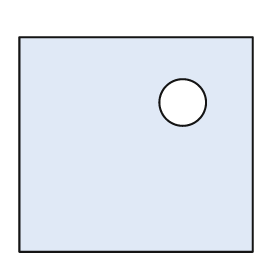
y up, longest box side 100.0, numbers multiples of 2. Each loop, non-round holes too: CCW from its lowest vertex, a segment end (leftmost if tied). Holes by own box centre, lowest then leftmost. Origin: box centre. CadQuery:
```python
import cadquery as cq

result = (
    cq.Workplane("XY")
    .moveTo(-50.0, -46.0)
    .lineTo(50.0, -46.0)
    .lineTo(50.0, 46.0)
    .lineTo(-50.0, 46.0)
    .close()
    .moveTo(20.0, 18.0)
    .circle(10.0)
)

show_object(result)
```